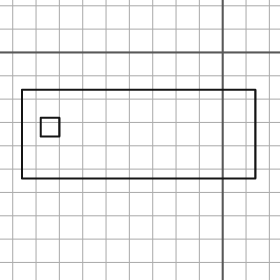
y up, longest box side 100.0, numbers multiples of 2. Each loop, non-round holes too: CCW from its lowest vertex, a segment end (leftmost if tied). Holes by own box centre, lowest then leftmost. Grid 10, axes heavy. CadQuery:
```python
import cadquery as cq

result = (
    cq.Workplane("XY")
    .moveTo(-86.0, -54.0)
    .lineTo(14.0, -54.0)
    .lineTo(14.0, -16.0)
    .lineTo(-86.0, -16.0)
    .close()
    .moveTo(-78.0, -36.0)
    .lineTo(-70.0, -36.0)
    .lineTo(-70.0, -28.0)
    .lineTo(-78.0, -28.0)
    .close()
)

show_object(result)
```